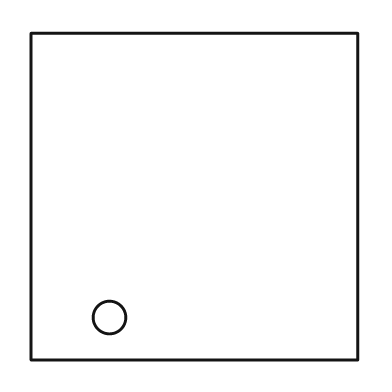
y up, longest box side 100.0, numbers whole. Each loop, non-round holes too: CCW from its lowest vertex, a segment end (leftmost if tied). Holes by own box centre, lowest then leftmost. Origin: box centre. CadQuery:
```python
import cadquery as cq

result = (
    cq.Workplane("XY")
    .moveTo(-50.0, -50.0)
    .lineTo(50.0, -50.0)
    .lineTo(50.0, 50.0)
    .lineTo(-50.0, 50.0)
    .close()
    .moveTo(-26.0, -37.0)
    .circle(5.0)
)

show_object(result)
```